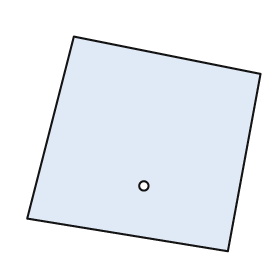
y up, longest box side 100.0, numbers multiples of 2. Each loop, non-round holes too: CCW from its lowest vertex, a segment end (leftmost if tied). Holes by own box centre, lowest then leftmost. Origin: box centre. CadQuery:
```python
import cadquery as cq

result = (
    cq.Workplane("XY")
    .moveTo(36.0, -46.0)
    .lineTo(50.0, 30.0)
    .lineTo(-30.0, 46.0)
    .lineTo(-50.0, -32.0)
    .close()
    .moveTo(0.0, -18.0)
    .circle(2.0)
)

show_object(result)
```